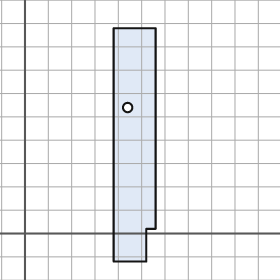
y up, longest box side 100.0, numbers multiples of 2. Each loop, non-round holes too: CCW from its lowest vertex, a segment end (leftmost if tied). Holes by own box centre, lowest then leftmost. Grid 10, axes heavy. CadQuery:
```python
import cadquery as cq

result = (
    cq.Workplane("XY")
    .moveTo(38.0, -12.0)
    .lineTo(52.0, -12.0)
    .lineTo(52.0, 2.0)
    .lineTo(56.0, 2.0)
    .lineTo(56.0, 88.0)
    .lineTo(38.0, 88.0)
    .close()
    .moveTo(44.0, 54.0)
    .circle(2.0)
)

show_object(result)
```